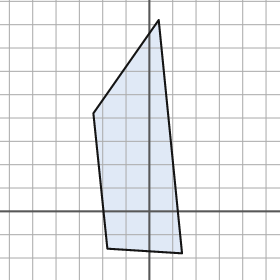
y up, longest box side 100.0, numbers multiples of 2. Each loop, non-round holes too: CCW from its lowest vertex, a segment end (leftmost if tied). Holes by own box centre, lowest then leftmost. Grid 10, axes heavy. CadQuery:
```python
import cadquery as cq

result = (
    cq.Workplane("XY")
    .moveTo(14.0, -18.0)
    .lineTo(4.0, 82.0)
    .lineTo(-24.0, 42.0)
    .lineTo(-18.0, -16.0)
    .close()
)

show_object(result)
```